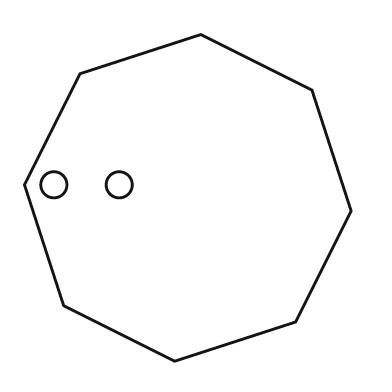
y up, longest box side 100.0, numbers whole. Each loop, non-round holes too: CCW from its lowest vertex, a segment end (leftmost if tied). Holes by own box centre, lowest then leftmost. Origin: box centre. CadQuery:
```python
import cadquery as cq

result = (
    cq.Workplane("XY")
    .moveTo(-4.0, -50.0)
    .lineTo(33.0, -38.0)
    .lineTo(50.0, -4.0)
    .lineTo(38.0, 33.0)
    .lineTo(4.0, 50.0)
    .lineTo(-33.0, 38.0)
    .lineTo(-50.0, 4.0)
    .lineTo(-38.0, -33.0)
    .close()
    .moveTo(-41.0, 4.0)
    .circle(4.0)
    .moveTo(-21.0, 4.0)
    .circle(4.0)
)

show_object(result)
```